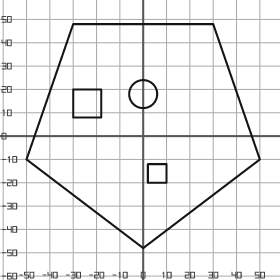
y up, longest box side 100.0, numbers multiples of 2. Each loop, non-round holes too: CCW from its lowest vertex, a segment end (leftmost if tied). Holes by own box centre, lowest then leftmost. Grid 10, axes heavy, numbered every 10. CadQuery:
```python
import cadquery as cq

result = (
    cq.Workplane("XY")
    .moveTo(0.0, -48.0)
    .lineTo(50.0, -10.0)
    .lineTo(30.0, 48.0)
    .lineTo(-30.0, 48.0)
    .lineTo(-50.0, -10.0)
    .close()
    .moveTo(2.0, -20.0)
    .lineTo(10.0, -20.0)
    .lineTo(10.0, -12.0)
    .lineTo(2.0, -12.0)
    .close()
    .moveTo(-30.0, 8.0)
    .lineTo(-18.0, 8.0)
    .lineTo(-18.0, 20.0)
    .lineTo(-30.0, 20.0)
    .close()
    .moveTo(0.0, 18.0)
    .circle(6.0)
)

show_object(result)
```